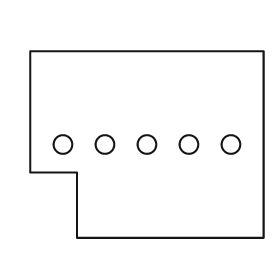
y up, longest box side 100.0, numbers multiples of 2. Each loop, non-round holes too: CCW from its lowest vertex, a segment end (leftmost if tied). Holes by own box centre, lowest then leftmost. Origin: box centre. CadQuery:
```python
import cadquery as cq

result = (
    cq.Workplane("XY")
    .moveTo(-30.0, -40.0)
    .lineTo(50.0, -40.0)
    .lineTo(50.0, 40.0)
    .lineTo(-50.0, 40.0)
    .lineTo(-50.0, -12.0)
    .lineTo(-30.0, -12.0)
    .close()
    .moveTo(-36.0, 0.0)
    .circle(4.0)
    .moveTo(-18.0, 0.0)
    .circle(4.0)
    .moveTo(0.0, 0.0)
    .circle(4.0)
    .moveTo(18.0, 0.0)
    .circle(4.0)
    .moveTo(36.0, 0.0)
    .circle(4.0)
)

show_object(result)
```